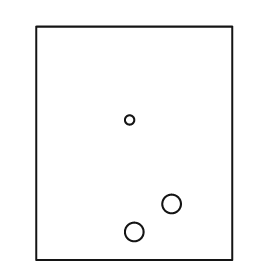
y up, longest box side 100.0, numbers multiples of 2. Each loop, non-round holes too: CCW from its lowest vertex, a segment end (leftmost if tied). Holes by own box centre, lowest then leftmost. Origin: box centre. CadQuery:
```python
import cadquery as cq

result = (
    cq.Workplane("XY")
    .moveTo(-42.0, -50.0)
    .lineTo(42.0, -50.0)
    .lineTo(42.0, 50.0)
    .lineTo(-42.0, 50.0)
    .close()
    .moveTo(0.0, -38.0)
    .circle(4.0)
    .moveTo(16.0, -26.0)
    .circle(4.0)
    .moveTo(-2.0, 10.0)
    .circle(2.0)
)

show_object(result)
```